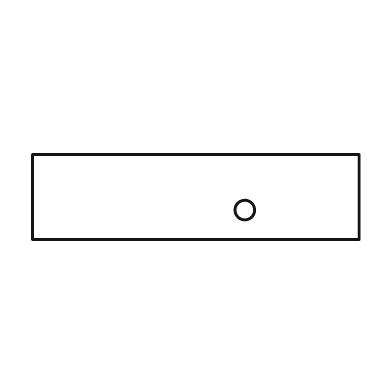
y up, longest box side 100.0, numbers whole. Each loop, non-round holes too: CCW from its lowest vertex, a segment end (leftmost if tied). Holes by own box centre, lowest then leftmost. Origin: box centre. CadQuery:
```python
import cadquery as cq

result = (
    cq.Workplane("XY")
    .moveTo(-50.0, -13.0)
    .lineTo(50.0, -13.0)
    .lineTo(50.0, 13.0)
    .lineTo(-50.0, 13.0)
    .close()
    .moveTo(15.0, -4.0)
    .circle(3.0)
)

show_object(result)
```